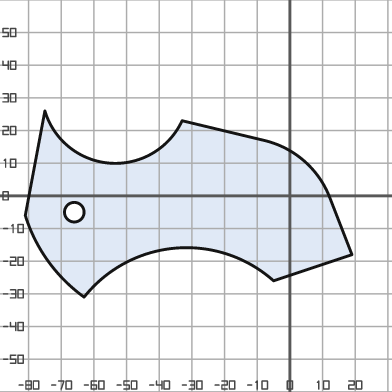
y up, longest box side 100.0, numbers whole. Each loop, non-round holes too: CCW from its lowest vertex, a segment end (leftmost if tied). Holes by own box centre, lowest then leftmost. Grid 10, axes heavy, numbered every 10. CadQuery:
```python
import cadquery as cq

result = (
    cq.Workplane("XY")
    .moveTo(-63.0, -31.0)
    .threePointArc((-35.0, -16.0), (-5.0, -26.0))
    .lineTo(19.0, -18.0)
    .lineTo(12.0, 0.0)
    .threePointArc((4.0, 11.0), (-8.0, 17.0))
    .lineTo(-33.0, 23.0)
    .threePointArc((-55.0, 10.0), (-75.0, 26.0))
    .lineTo(-81.0, -6.0)
    .threePointArc((-74.0, -20.0), (-63.0, -31.0))
    .close()
    .moveTo(-66.0, -5.0)
    .circle(3.0)
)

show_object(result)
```